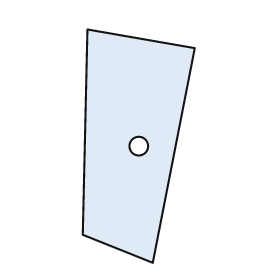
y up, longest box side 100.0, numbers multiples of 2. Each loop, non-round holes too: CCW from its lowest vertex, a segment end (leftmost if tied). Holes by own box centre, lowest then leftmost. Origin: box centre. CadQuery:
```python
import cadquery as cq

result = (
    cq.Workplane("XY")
    .moveTo(6.0, -50.0)
    .lineTo(24.0, 42.0)
    .lineTo(-22.0, 50.0)
    .lineTo(-24.0, -38.0)
    .close()
    .moveTo(0.0, 0.0)
    .circle(4.0)
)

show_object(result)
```